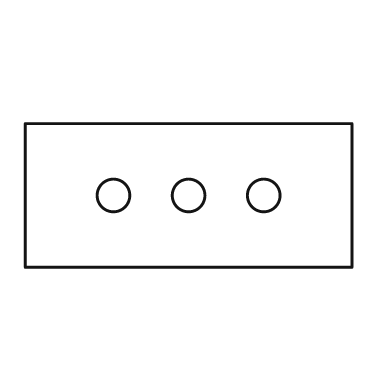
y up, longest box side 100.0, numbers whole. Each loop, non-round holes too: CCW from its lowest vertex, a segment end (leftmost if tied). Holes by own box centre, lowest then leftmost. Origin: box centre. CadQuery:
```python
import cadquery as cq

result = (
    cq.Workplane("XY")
    .moveTo(-50.0, -22.0)
    .lineTo(50.0, -22.0)
    .lineTo(50.0, 22.0)
    .lineTo(-50.0, 22.0)
    .close()
    .moveTo(-23.0, 0.0)
    .circle(5.0)
    .moveTo(0.0, 0.0)
    .circle(5.0)
    .moveTo(23.0, 0.0)
    .circle(5.0)
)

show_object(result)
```